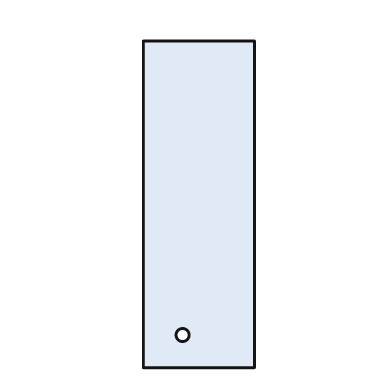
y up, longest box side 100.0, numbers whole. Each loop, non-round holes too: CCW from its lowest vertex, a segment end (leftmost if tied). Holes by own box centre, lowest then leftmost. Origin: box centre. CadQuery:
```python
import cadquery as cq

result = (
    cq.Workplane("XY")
    .moveTo(-17.0, -50.0)
    .lineTo(17.0, -50.0)
    .lineTo(17.0, 50.0)
    .lineTo(-17.0, 50.0)
    .close()
    .moveTo(-5.0, -40.0)
    .circle(2.0)
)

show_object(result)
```